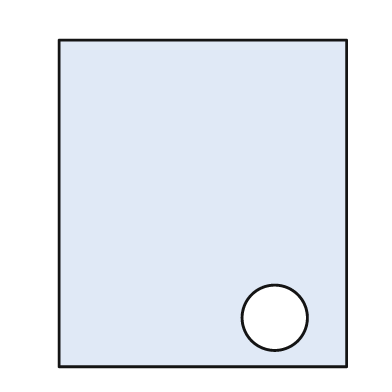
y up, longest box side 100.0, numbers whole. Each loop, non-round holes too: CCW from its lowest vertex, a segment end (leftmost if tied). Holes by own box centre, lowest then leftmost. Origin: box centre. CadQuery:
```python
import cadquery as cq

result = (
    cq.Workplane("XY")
    .moveTo(-44.0, -50.0)
    .lineTo(44.0, -50.0)
    .lineTo(44.0, 50.0)
    .lineTo(-44.0, 50.0)
    .close()
    .moveTo(22.0, -35.0)
    .circle(10.0)
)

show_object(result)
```